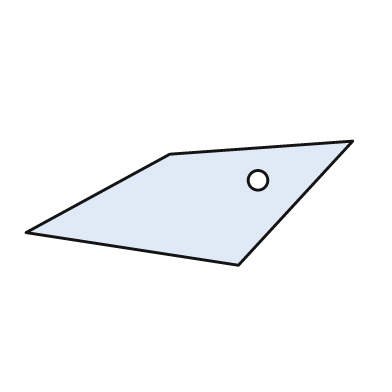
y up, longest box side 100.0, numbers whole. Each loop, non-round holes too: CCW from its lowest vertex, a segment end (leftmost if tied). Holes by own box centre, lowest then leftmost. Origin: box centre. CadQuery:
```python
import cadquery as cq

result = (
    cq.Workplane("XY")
    .moveTo(15.0, -19.0)
    .lineTo(50.0, 19.0)
    .lineTo(-6.0, 15.0)
    .lineTo(-50.0, -9.0)
    .close()
    .moveTo(21.0, 7.0)
    .circle(3.0)
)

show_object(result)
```